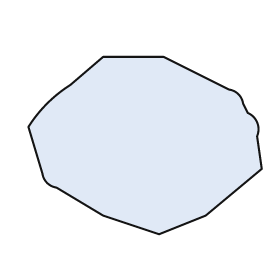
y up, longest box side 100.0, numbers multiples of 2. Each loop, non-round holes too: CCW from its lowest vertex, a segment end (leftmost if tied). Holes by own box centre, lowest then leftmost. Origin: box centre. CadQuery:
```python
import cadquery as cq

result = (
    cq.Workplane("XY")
    .moveTo(6.0, -38.0)
    .lineTo(26.0, -30.0)
    .lineTo(50.0, -10.0)
    .lineTo(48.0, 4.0)
    .threePointArc((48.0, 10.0), (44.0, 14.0))
    .lineTo(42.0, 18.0)
    .threePointArc((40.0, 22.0), (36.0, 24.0))
    .lineTo(8.0, 38.0)
    .lineTo(-18.0, 38.0)
    .lineTo(-32.0, 26.0)
    .threePointArc((-42.0, 18.0), (-50.0, 8.0))
    .lineTo(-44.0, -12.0)
    .threePointArc((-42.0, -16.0), (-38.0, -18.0))
    .lineTo(-18.0, -30.0)
    .close()
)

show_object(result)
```